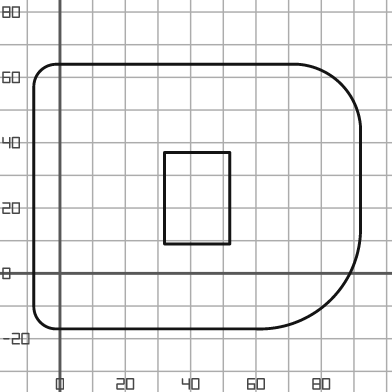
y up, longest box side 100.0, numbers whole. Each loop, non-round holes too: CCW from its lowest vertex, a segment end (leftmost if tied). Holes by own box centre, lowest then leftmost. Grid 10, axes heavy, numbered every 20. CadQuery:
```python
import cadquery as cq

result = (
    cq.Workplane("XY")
    .moveTo(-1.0, -17.0)
    .lineTo(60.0, -17.0)
    .threePointArc((83.0, -8.0), (92.0, 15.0))
    .lineTo(92.0, 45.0)
    .threePointArc((86.0, 58.0), (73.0, 64.0))
    .lineTo(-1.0, 64.0)
    .threePointArc((-6.0, 62.0), (-8.0, 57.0))
    .lineTo(-8.0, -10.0)
    .threePointArc((-6.0, -15.0), (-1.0, -17.0))
    .close()
    .moveTo(32.0, 9.0)
    .lineTo(52.0, 9.0)
    .lineTo(52.0, 37.0)
    .lineTo(32.0, 37.0)
    .close()
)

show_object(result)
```